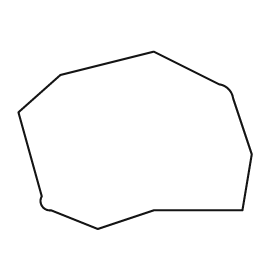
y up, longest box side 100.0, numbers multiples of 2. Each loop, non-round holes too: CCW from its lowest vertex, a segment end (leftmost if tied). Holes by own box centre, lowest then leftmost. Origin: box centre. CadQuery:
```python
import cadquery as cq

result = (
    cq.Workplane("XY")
    .moveTo(-16.0, -38.0)
    .lineTo(8.0, -30.0)
    .lineTo(46.0, -30.0)
    .lineTo(50.0, -6.0)
    .lineTo(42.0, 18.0)
    .threePointArc((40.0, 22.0), (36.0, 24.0))
    .lineTo(8.0, 38.0)
    .lineTo(-32.0, 28.0)
    .lineTo(-50.0, 12.0)
    .lineTo(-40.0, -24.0)
    .threePointArc((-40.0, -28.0), (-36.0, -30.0))
    .close()
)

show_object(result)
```